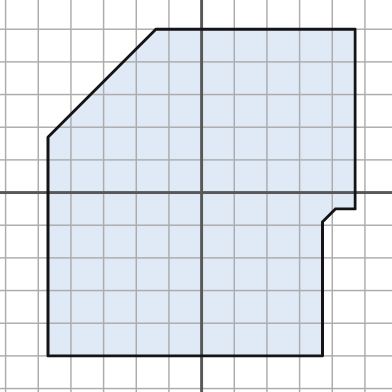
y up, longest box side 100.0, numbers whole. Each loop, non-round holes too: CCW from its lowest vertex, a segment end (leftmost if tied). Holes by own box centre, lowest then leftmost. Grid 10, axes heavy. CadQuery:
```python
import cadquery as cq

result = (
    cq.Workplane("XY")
    .moveTo(-47.0, -50.0)
    .lineTo(37.0, -50.0)
    .lineTo(37.0, -9.0)
    .lineTo(41.0, -5.0)
    .lineTo(47.0, -5.0)
    .lineTo(47.0, 50.0)
    .lineTo(-14.0, 50.0)
    .lineTo(-47.0, 17.0)
    .close()
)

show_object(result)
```